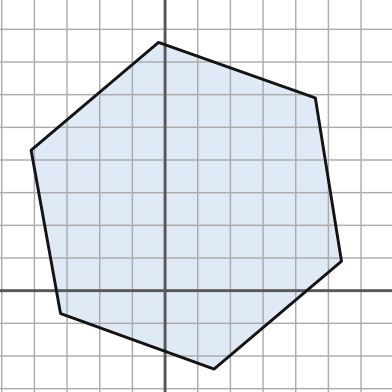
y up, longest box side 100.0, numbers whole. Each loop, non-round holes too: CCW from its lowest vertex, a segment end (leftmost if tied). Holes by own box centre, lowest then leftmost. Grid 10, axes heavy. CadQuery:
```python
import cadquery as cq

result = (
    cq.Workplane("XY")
    .moveTo(15.0, -24.0)
    .lineTo(54.0, 9.0)
    .lineTo(46.0, 59.0)
    .lineTo(-2.0, 76.0)
    .lineTo(-41.0, 43.0)
    .lineTo(-32.0, -7.0)
    .close()
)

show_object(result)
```